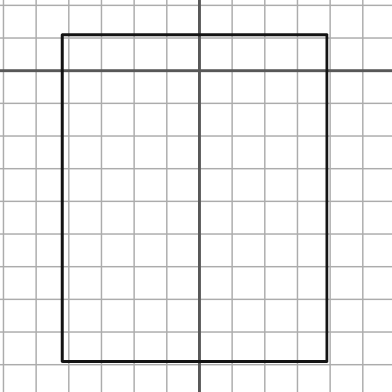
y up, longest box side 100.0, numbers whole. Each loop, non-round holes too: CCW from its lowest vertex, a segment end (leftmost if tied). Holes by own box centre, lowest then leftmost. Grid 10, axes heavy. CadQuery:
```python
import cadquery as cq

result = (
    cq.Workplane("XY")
    .moveTo(-42.0, -89.0)
    .lineTo(39.0, -89.0)
    .lineTo(39.0, 11.0)
    .lineTo(-42.0, 11.0)
    .close()
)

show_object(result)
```